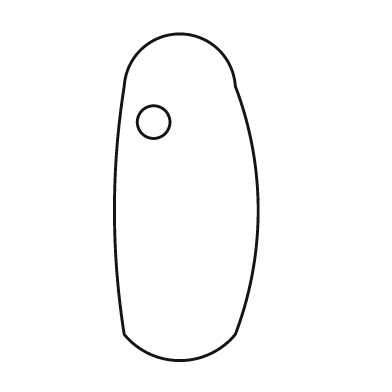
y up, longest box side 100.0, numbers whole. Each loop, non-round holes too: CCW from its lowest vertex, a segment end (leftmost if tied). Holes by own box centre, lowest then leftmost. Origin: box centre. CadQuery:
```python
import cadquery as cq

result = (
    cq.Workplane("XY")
    .moveTo(-19.0, -42.0)
    .threePointArc((-2.0, -50.0), (15.0, -42.0))
    .threePointArc((22.0, -4.0), (15.0, 34.0))
    .threePointArc((-2.0, 50.0), (-19.0, 34.0))
    .threePointArc((-22.0, -4.0), (-19.0, -42.0))
    .close()
    .moveTo(-10.0, 23.0)
    .circle(5.0)
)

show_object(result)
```